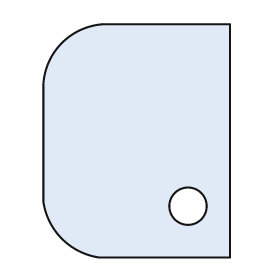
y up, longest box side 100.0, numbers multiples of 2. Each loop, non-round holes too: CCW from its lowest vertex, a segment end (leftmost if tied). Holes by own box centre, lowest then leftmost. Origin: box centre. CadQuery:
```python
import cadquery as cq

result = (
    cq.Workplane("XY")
    .moveTo(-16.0, -50.0)
    .lineTo(40.0, -50.0)
    .lineTo(40.0, 50.0)
    .lineTo(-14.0, 50.0)
    .threePointArc((-32.0, 42.0), (-40.0, 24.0))
    .lineTo(-40.0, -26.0)
    .threePointArc((-32.0, -42.0), (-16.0, -50.0))
    .close()
    .moveTo(22.0, -28.0)
    .circle(8.0)
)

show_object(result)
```